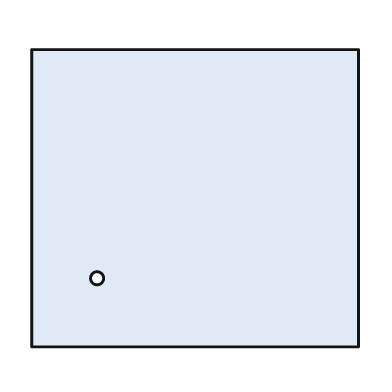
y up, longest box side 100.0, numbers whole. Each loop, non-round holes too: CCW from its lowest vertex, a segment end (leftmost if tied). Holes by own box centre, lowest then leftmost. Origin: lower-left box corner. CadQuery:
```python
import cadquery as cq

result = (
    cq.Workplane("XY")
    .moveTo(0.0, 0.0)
    .lineTo(100.0, 0.0)
    .lineTo(100.0, 91.0)
    .lineTo(0.0, 91.0)
    .close()
    .moveTo(20.0, 21.0)
    .circle(2.0)
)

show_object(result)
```